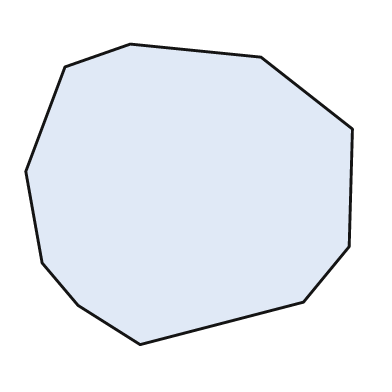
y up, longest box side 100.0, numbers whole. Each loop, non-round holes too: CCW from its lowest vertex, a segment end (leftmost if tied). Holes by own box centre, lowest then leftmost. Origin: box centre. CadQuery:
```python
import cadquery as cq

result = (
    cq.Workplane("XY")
    .moveTo(-15.0, -46.0)
    .lineTo(35.0, -33.0)
    .lineTo(49.0, -16.0)
    .lineTo(50.0, 20.0)
    .lineTo(22.0, 42.0)
    .lineTo(-18.0, 46.0)
    .lineTo(-38.0, 39.0)
    .lineTo(-50.0, 7.0)
    .lineTo(-45.0, -21.0)
    .lineTo(-34.0, -34.0)
    .close()
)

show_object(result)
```